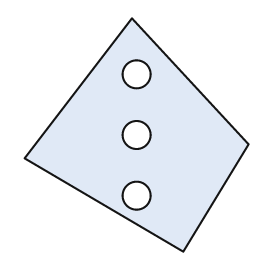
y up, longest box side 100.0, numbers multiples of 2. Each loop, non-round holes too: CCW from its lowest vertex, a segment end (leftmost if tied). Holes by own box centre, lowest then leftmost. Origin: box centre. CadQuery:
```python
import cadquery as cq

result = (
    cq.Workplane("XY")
    .moveTo(20.0, -50.0)
    .lineTo(48.0, -4.0)
    .lineTo(-2.0, 50.0)
    .lineTo(-48.0, -10.0)
    .close()
    .moveTo(0.0, -26.0)
    .circle(6.0)
    .moveTo(0.0, 0.0)
    .circle(6.0)
    .moveTo(0.0, 26.0)
    .circle(6.0)
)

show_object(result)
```